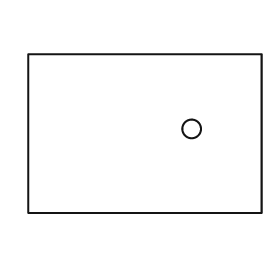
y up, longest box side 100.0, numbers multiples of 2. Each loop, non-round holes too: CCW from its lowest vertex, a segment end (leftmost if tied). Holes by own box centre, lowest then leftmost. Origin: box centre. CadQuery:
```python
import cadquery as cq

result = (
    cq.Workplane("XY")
    .moveTo(-50.0, -34.0)
    .lineTo(50.0, -34.0)
    .lineTo(50.0, 34.0)
    .lineTo(-50.0, 34.0)
    .close()
    .moveTo(20.0, 2.0)
    .circle(4.0)
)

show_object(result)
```